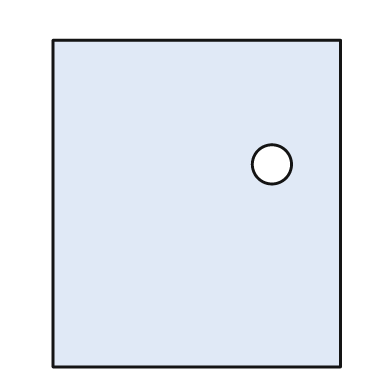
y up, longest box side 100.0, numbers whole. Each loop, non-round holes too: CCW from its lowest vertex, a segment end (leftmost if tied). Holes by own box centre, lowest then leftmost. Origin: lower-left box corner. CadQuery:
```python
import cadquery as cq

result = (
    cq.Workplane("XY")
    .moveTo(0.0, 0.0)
    .lineTo(88.0, 0.0)
    .lineTo(88.0, 100.0)
    .lineTo(0.0, 100.0)
    .close()
    .moveTo(67.0, 62.0)
    .circle(6.0)
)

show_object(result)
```